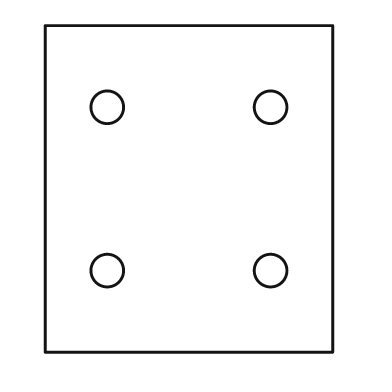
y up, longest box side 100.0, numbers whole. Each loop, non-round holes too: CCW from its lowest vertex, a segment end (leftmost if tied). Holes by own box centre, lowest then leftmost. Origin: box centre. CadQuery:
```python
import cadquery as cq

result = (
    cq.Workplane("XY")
    .moveTo(-44.0, -50.0)
    .lineTo(44.0, -50.0)
    .lineTo(44.0, 50.0)
    .lineTo(-44.0, 50.0)
    .close()
    .moveTo(-25.0, -25.0)
    .circle(5.0)
    .moveTo(25.0, -25.0)
    .circle(5.0)
    .moveTo(-25.0, 25.0)
    .circle(5.0)
    .moveTo(25.0, 25.0)
    .circle(5.0)
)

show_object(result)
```